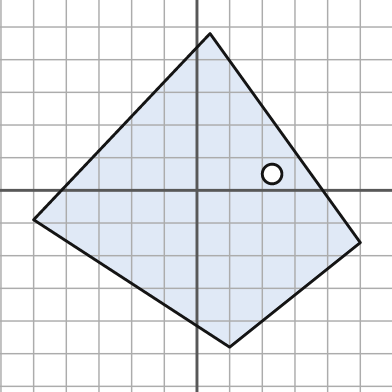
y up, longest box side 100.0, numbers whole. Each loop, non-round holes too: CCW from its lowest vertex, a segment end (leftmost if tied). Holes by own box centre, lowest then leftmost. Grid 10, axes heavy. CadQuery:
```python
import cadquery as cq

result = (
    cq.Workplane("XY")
    .moveTo(10.0, -48.0)
    .lineTo(50.0, -16.0)
    .lineTo(4.0, 48.0)
    .lineTo(-50.0, -9.0)
    .close()
    .moveTo(23.0, 5.0)
    .circle(3.0)
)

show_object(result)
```